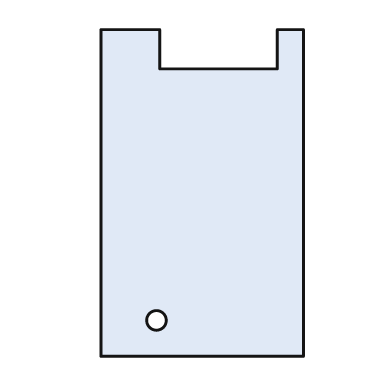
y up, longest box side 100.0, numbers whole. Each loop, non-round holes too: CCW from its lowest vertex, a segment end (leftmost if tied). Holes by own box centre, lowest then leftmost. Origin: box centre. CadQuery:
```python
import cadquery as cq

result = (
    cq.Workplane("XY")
    .moveTo(-31.0, -50.0)
    .lineTo(31.0, -50.0)
    .lineTo(31.0, 50.0)
    .lineTo(23.0, 50.0)
    .lineTo(23.0, 38.0)
    .lineTo(-13.0, 38.0)
    .lineTo(-13.0, 50.0)
    .lineTo(-31.0, 50.0)
    .close()
    .moveTo(-14.0, -39.0)
    .circle(3.0)
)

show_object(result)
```